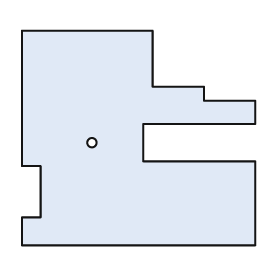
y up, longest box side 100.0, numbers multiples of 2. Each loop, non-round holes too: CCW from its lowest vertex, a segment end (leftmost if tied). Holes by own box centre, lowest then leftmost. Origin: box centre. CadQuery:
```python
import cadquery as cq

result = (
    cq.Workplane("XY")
    .moveTo(-50.0, -46.0)
    .lineTo(50.0, -46.0)
    .lineTo(50.0, -10.0)
    .lineTo(2.0, -10.0)
    .lineTo(2.0, 6.0)
    .lineTo(50.0, 6.0)
    .lineTo(50.0, 16.0)
    .lineTo(28.0, 16.0)
    .lineTo(28.0, 22.0)
    .lineTo(6.0, 22.0)
    .lineTo(6.0, 46.0)
    .lineTo(-50.0, 46.0)
    .lineTo(-50.0, -12.0)
    .lineTo(-42.0, -12.0)
    .lineTo(-42.0, -34.0)
    .lineTo(-50.0, -34.0)
    .close()
    .moveTo(-20.0, -2.0)
    .circle(2.0)
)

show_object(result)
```